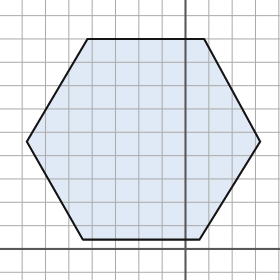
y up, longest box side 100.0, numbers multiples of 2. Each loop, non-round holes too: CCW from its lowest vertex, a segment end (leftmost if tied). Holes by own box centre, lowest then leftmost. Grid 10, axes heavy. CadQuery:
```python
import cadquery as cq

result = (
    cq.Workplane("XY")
    .moveTo(-44.0, 4.0)
    .lineTo(6.0, 4.0)
    .lineTo(32.0, 46.0)
    .lineTo(8.0, 90.0)
    .lineTo(-42.0, 90.0)
    .lineTo(-68.0, 46.0)
    .close()
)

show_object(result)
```